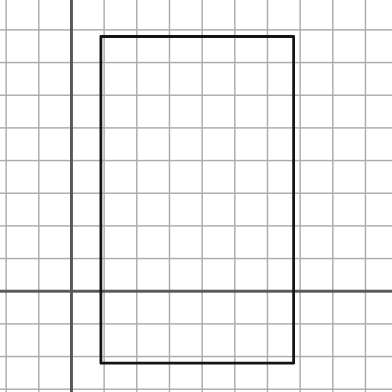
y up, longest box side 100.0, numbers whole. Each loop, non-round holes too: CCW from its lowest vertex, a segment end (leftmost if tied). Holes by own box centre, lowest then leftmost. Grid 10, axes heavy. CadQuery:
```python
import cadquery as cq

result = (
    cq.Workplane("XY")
    .moveTo(9.0, -22.0)
    .lineTo(68.0, -22.0)
    .lineTo(68.0, 78.0)
    .lineTo(9.0, 78.0)
    .close()
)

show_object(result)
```